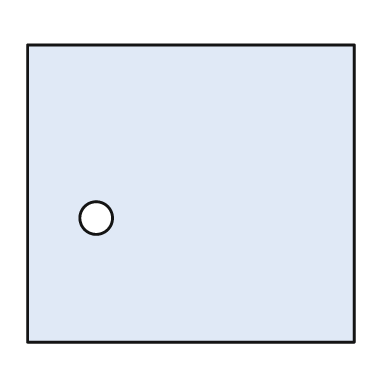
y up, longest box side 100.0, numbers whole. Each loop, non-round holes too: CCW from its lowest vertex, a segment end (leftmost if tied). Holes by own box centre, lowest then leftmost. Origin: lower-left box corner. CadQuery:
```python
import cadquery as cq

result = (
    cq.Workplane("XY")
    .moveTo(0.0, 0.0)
    .lineTo(100.0, 0.0)
    .lineTo(100.0, 91.0)
    .lineTo(0.0, 91.0)
    .close()
    .moveTo(21.0, 38.0)
    .circle(5.0)
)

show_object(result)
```